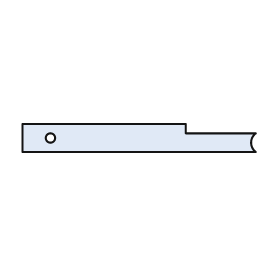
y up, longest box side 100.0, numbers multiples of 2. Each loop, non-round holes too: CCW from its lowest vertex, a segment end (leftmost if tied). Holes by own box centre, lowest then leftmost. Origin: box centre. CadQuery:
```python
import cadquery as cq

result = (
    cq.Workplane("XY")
    .moveTo(-50.0, -6.0)
    .lineTo(50.0, -6.0)
    .threePointArc((48.0, -2.0), (50.0, 2.0))
    .lineTo(20.0, 2.0)
    .lineTo(20.0, 6.0)
    .lineTo(-50.0, 6.0)
    .close()
    .moveTo(-38.0, 0.0)
    .circle(2.0)
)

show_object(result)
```